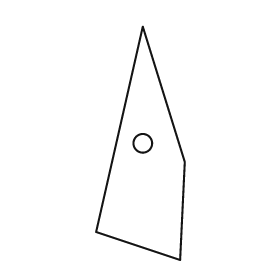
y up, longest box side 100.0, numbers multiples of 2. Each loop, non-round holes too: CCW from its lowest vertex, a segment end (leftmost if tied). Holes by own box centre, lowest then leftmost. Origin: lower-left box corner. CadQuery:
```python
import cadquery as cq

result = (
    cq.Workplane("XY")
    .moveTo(36.0, 0.0)
    .lineTo(38.0, 42.0)
    .lineTo(20.0, 100.0)
    .lineTo(0.0, 12.0)
    .close()
    .moveTo(20.0, 50.0)
    .circle(4.0)
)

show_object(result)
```